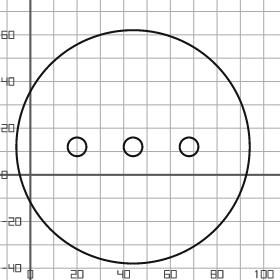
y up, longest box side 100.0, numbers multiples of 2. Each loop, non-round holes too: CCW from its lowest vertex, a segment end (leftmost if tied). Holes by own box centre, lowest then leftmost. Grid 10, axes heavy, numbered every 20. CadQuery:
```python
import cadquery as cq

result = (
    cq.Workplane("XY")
    .moveTo(44.0, 12.0)
    .circle(50.0)
    .moveTo(20.0, 12.0)
    .circle(4.0)
    .moveTo(44.0, 12.0)
    .circle(4.0)
    .moveTo(68.0, 12.0)
    .circle(4.0)
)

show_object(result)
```